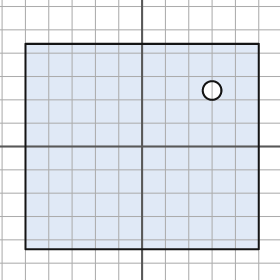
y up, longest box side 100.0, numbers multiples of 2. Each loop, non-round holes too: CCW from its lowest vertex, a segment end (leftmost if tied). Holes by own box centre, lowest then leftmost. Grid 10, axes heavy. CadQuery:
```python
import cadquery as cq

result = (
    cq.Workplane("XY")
    .moveTo(-50.0, -44.0)
    .lineTo(50.0, -44.0)
    .lineTo(50.0, 44.0)
    .lineTo(-50.0, 44.0)
    .close()
    .moveTo(30.0, 24.0)
    .circle(4.0)
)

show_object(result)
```